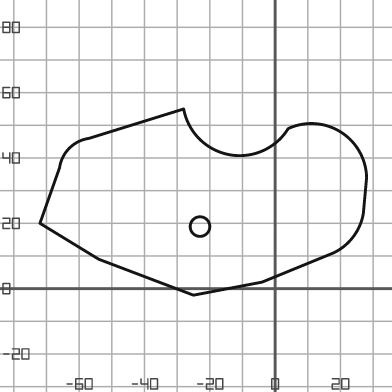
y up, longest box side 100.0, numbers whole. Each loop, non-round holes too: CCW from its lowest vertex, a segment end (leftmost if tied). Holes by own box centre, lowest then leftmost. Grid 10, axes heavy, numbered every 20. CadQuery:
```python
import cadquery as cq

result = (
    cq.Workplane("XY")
    .moveTo(-25.0, -2.0)
    .lineTo(-4.0, 2.0)
    .lineTo(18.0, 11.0)
    .threePointArc((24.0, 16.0), (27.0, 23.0))
    .lineTo(28.0, 34.0)
    .threePointArc((20.0, 48.0), (4.0, 49.0))
    .threePointArc((-14.0, 41.0), (-28.0, 55.0))
    .lineTo(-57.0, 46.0)
    .threePointArc((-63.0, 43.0), (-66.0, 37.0))
    .lineTo(-72.0, 20.0)
    .lineTo(-54.0, 9.0)
    .close()
    .moveTo(-23.0, 19.0)
    .circle(3.0)
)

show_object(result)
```